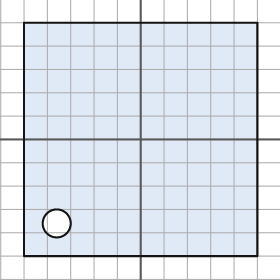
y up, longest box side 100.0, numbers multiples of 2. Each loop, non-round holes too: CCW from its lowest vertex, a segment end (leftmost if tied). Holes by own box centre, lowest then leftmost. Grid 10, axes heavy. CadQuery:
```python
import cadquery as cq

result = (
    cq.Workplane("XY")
    .moveTo(-50.0, -50.0)
    .lineTo(50.0, -50.0)
    .lineTo(50.0, 50.0)
    .lineTo(-50.0, 50.0)
    .close()
    .moveTo(-36.0, -36.0)
    .circle(6.0)
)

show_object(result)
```